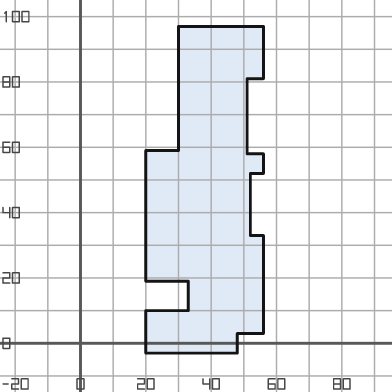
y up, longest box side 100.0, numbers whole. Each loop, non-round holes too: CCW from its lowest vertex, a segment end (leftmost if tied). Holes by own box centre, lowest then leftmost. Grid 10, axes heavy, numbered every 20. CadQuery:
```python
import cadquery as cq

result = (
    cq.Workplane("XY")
    .moveTo(20.0, -3.0)
    .lineTo(48.0, -3.0)
    .lineTo(48.0, 3.0)
    .lineTo(56.0, 3.0)
    .lineTo(56.0, 33.0)
    .lineTo(52.0, 33.0)
    .lineTo(52.0, 52.0)
    .lineTo(56.0, 52.0)
    .lineTo(56.0, 58.0)
    .lineTo(51.0, 58.0)
    .lineTo(51.0, 81.0)
    .lineTo(56.0, 81.0)
    .lineTo(56.0, 97.0)
    .lineTo(30.0, 97.0)
    .lineTo(30.0, 59.0)
    .lineTo(20.0, 59.0)
    .lineTo(20.0, 19.0)
    .lineTo(33.0, 19.0)
    .lineTo(33.0, 10.0)
    .lineTo(20.0, 10.0)
    .close()
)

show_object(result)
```